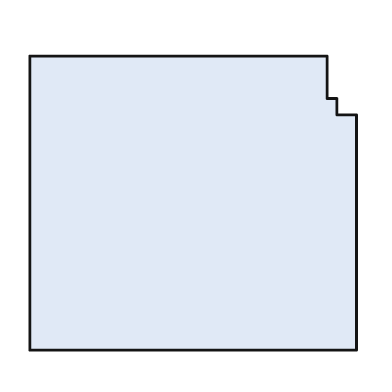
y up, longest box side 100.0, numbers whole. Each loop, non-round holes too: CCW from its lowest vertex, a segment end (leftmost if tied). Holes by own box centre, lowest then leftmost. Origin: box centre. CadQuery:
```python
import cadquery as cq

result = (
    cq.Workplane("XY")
    .moveTo(-50.0, -45.0)
    .lineTo(50.0, -45.0)
    .lineTo(50.0, 27.0)
    .lineTo(44.0, 27.0)
    .lineTo(44.0, 32.0)
    .lineTo(41.0, 32.0)
    .lineTo(41.0, 45.0)
    .lineTo(-50.0, 45.0)
    .close()
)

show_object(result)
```